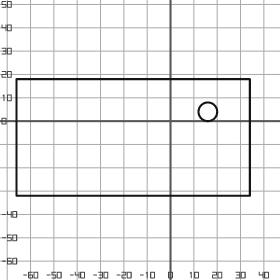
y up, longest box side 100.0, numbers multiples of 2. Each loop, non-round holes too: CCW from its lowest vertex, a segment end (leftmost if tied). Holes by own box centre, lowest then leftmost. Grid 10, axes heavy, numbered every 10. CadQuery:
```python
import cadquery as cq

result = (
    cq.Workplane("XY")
    .moveTo(-66.0, -32.0)
    .lineTo(34.0, -32.0)
    .lineTo(34.0, 18.0)
    .lineTo(-66.0, 18.0)
    .close()
    .moveTo(16.0, 4.0)
    .circle(4.0)
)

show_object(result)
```